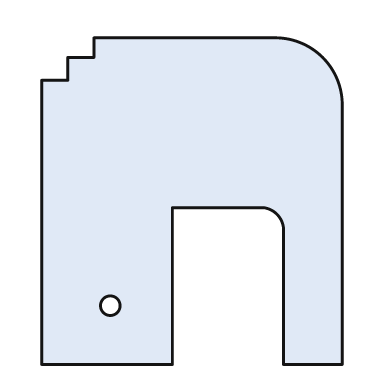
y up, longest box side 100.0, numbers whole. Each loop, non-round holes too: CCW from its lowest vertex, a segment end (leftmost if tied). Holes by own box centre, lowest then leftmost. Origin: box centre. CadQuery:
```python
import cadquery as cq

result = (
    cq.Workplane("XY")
    .moveTo(-46.0, -50.0)
    .lineTo(-6.0, -50.0)
    .lineTo(-6.0, -2.0)
    .lineTo(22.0, -2.0)
    .threePointArc((26.0, -4.0), (28.0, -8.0))
    .lineTo(28.0, -50.0)
    .lineTo(46.0, -50.0)
    .lineTo(46.0, 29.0)
    .threePointArc((40.0, 44.0), (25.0, 50.0))
    .lineTo(-30.0, 50.0)
    .lineTo(-30.0, 44.0)
    .lineTo(-38.0, 44.0)
    .lineTo(-38.0, 37.0)
    .lineTo(-46.0, 37.0)
    .close()
    .moveTo(-25.0, -32.0)
    .circle(3.0)
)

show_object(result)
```